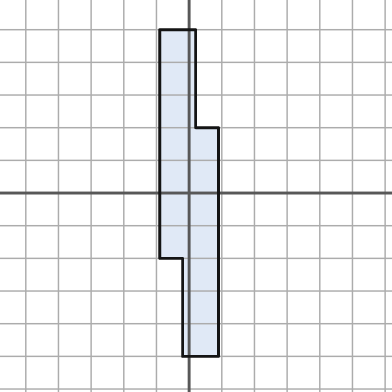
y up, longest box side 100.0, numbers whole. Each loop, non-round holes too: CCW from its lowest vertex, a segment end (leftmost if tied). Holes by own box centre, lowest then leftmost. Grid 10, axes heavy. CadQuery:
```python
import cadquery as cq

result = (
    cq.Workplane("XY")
    .moveTo(-2.0, -50.0)
    .lineTo(9.0, -50.0)
    .lineTo(9.0, 20.0)
    .lineTo(2.0, 20.0)
    .lineTo(2.0, 50.0)
    .lineTo(-9.0, 50.0)
    .lineTo(-9.0, -20.0)
    .lineTo(-2.0, -20.0)
    .close()
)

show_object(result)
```